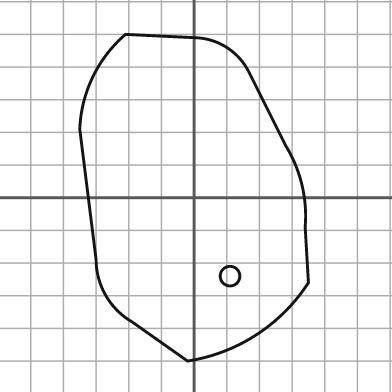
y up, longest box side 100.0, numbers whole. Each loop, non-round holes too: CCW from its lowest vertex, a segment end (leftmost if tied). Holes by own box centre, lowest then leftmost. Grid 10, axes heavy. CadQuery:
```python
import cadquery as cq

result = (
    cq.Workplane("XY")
    .moveTo(-2.0, -50.0)
    .threePointArc((19.0, -42.0), (35.0, -26.0))
    .lineTo(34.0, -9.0)
    .threePointArc((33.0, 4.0), (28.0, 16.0))
    .lineTo(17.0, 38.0)
    .threePointArc((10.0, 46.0), (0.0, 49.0))
    .lineTo(-21.0, 50.0)
    .threePointArc((-31.0, 37.0), (-35.0, 21.0))
    .lineTo(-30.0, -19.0)
    .threePointArc((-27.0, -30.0), (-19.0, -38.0))
    .close()
    .moveTo(11.0, -24.0)
    .circle(3.0)
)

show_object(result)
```